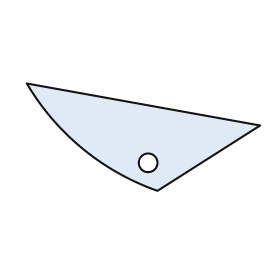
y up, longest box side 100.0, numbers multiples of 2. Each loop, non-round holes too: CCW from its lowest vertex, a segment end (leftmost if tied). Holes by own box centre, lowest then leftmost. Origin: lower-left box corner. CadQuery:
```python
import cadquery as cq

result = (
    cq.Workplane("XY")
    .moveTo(56.0, 0.0)
    .lineTo(100.0, 28.0)
    .lineTo(0.0, 46.0)
    .threePointArc((24.0, 18.0), (56.0, 0.0))
    .close()
    .moveTo(52.0, 12.0)
    .circle(4.0)
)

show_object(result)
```